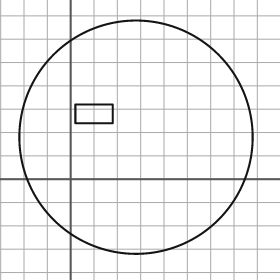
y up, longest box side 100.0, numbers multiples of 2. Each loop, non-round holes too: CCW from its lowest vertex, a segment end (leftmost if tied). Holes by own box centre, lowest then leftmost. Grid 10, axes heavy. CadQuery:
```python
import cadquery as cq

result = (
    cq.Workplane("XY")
    .moveTo(28.0, 18.0)
    .circle(50.0)
    .moveTo(2.0, 24.0)
    .lineTo(18.0, 24.0)
    .lineTo(18.0, 32.0)
    .lineTo(2.0, 32.0)
    .close()
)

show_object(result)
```